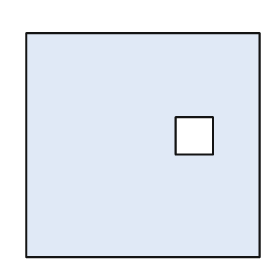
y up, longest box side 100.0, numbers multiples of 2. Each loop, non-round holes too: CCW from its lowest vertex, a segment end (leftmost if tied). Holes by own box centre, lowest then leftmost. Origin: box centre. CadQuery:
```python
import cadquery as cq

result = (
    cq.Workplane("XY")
    .moveTo(-50.0, -48.0)
    .lineTo(50.0, -48.0)
    .lineTo(50.0, 48.0)
    .lineTo(-50.0, 48.0)
    .close()
    .moveTo(14.0, -4.0)
    .lineTo(30.0, -4.0)
    .lineTo(30.0, 12.0)
    .lineTo(14.0, 12.0)
    .close()
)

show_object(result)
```